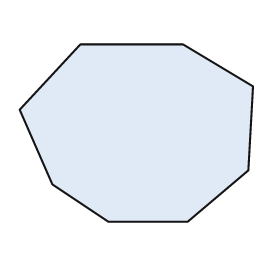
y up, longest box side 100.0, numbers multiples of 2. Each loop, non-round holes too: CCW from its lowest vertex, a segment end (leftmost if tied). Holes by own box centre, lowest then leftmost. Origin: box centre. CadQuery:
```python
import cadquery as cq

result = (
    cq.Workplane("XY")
    .moveTo(-12.0, -38.0)
    .lineTo(22.0, -38.0)
    .lineTo(48.0, -16.0)
    .lineTo(50.0, 20.0)
    .lineTo(20.0, 38.0)
    .lineTo(-24.0, 38.0)
    .lineTo(-50.0, 10.0)
    .lineTo(-36.0, -22.0)
    .close()
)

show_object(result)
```